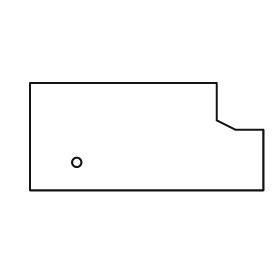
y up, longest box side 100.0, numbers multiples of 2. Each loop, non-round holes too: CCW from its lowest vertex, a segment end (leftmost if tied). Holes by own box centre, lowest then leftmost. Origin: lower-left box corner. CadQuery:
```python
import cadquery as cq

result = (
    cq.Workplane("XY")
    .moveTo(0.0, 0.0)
    .lineTo(100.0, 0.0)
    .lineTo(100.0, 26.0)
    .lineTo(88.0, 26.0)
    .lineTo(80.0, 30.0)
    .lineTo(80.0, 46.0)
    .lineTo(0.0, 46.0)
    .close()
    .moveTo(20.0, 12.0)
    .circle(2.0)
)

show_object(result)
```